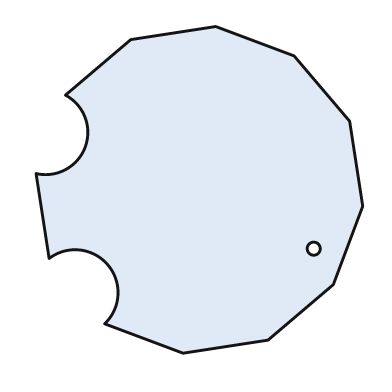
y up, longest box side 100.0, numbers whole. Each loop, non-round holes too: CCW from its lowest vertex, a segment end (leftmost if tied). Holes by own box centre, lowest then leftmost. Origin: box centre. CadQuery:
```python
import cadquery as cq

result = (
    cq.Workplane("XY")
    .moveTo(-5.0, -50.0)
    .lineTo(21.0, -46.0)
    .lineTo(41.0, -29.0)
    .lineTo(50.0, -5.0)
    .lineTo(46.0, 21.0)
    .lineTo(29.0, 41.0)
    .lineTo(5.0, 50.0)
    .lineTo(-21.0, 46.0)
    .lineTo(-41.0, 29.0)
    .threePointArc((-35.0, 13.0), (-50.0, 5.0))
    .lineTo(-46.0, -21.0)
    .threePointArc((-28.0, -23.0), (-29.0, -41.0))
    .close()
    .moveTo(35.0, -18.0)
    .circle(2.0)
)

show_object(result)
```